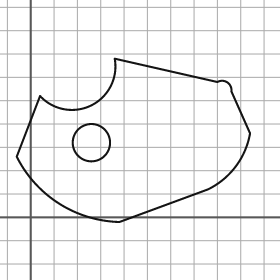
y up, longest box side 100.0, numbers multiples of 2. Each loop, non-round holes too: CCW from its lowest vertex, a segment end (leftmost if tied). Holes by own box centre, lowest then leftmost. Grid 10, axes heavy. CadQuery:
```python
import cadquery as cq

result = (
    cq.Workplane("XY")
    .moveTo(38.0, -2.0)
    .lineTo(76.0, 12.0)
    .threePointArc((88.0, 22.0), (94.0, 36.0))
    .lineTo(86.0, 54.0)
    .threePointArc((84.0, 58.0), (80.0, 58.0))
    .lineTo(36.0, 68.0)
    .threePointArc((26.0, 48.0), (4.0, 52.0))
    .lineTo(-6.0, 26.0)
    .threePointArc((12.0, 6.0), (38.0, -2.0))
    .close()
    .moveTo(26.0, 32.0)
    .circle(8.0)
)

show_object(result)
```